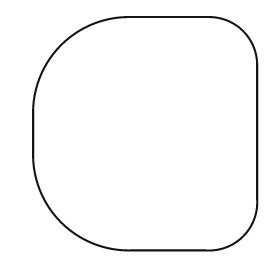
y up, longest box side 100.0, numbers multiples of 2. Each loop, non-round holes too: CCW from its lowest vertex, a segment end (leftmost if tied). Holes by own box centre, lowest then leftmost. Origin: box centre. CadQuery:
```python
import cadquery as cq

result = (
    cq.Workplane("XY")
    .moveTo(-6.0, -50.0)
    .lineTo(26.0, -50.0)
    .threePointArc((42.0, -44.0), (48.0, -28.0))
    .lineTo(48.0, 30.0)
    .threePointArc((42.0, 44.0), (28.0, 50.0))
    .lineTo(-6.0, 50.0)
    .threePointArc((-36.0, 38.0), (-48.0, 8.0))
    .lineTo(-48.0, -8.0)
    .threePointArc((-36.0, -38.0), (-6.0, -50.0))
    .close()
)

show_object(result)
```